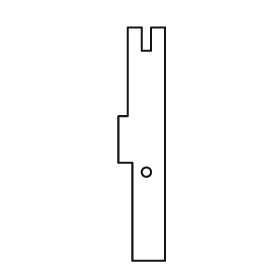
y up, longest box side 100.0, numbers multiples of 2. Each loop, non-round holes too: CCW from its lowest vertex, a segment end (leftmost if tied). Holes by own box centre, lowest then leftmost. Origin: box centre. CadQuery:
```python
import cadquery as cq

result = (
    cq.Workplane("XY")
    .moveTo(-4.0, -50.0)
    .lineTo(10.0, -50.0)
    .lineTo(10.0, 50.0)
    .lineTo(4.0, 50.0)
    .lineTo(4.0, 40.0)
    .lineTo(0.0, 40.0)
    .lineTo(0.0, 50.0)
    .lineTo(-6.0, 50.0)
    .lineTo(-6.0, 12.0)
    .lineTo(-10.0, 12.0)
    .lineTo(-10.0, -8.0)
    .lineTo(-4.0, -8.0)
    .close()
    .moveTo(2.0, -12.0)
    .circle(2.0)
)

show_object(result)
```